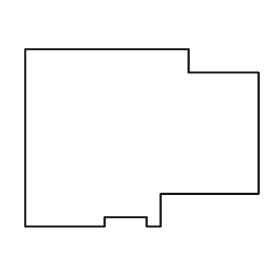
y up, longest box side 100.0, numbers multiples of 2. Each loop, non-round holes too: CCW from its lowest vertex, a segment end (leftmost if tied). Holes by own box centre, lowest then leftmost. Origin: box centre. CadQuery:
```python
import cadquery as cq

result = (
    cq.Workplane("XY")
    .moveTo(-50.0, -38.0)
    .lineTo(-16.0, -38.0)
    .lineTo(-16.0, -34.0)
    .lineTo(2.0, -34.0)
    .lineTo(2.0, -38.0)
    .lineTo(8.0, -38.0)
    .lineTo(8.0, -24.0)
    .lineTo(50.0, -24.0)
    .lineTo(50.0, 28.0)
    .lineTo(20.0, 28.0)
    .lineTo(20.0, 38.0)
    .lineTo(-50.0, 38.0)
    .close()
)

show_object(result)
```